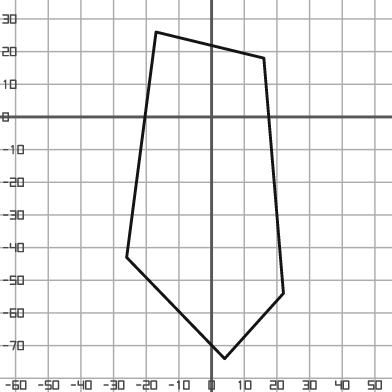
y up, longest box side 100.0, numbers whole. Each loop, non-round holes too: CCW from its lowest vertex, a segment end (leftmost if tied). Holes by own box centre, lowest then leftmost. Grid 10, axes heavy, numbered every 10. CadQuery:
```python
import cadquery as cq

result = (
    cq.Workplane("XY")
    .moveTo(4.0, -74.0)
    .lineTo(22.0, -54.0)
    .lineTo(16.0, 18.0)
    .lineTo(-17.0, 26.0)
    .lineTo(-26.0, -43.0)
    .close()
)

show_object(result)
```